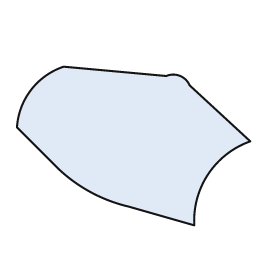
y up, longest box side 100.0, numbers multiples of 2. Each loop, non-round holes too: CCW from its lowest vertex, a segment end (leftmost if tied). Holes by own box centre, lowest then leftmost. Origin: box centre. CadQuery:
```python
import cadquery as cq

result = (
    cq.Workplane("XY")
    .moveTo(26.0, -34.0)
    .threePointArc((32.0, -12.0), (50.0, 2.0))
    .lineTo(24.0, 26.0)
    .threePointArc((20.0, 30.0), (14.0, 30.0))
    .lineTo(-30.0, 34.0)
    .threePointArc((-44.0, 24.0), (-50.0, 8.0))
    .lineTo(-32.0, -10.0)
    .threePointArc((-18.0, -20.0), (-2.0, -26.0))
    .close()
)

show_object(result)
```